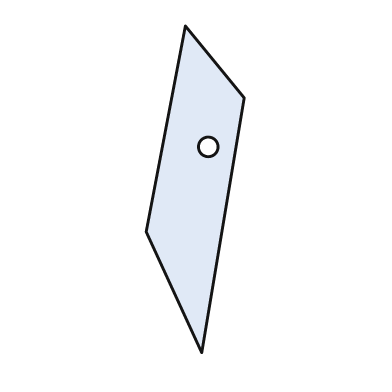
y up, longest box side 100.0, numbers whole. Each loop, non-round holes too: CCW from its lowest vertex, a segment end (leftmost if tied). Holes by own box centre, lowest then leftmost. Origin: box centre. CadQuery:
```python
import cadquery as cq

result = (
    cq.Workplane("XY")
    .moveTo(2.0, -50.0)
    .lineTo(15.0, 28.0)
    .lineTo(-3.0, 50.0)
    .lineTo(-15.0, -13.0)
    .close()
    .moveTo(4.0, 13.0)
    .circle(3.0)
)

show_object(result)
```